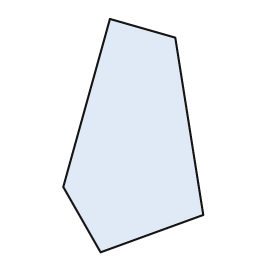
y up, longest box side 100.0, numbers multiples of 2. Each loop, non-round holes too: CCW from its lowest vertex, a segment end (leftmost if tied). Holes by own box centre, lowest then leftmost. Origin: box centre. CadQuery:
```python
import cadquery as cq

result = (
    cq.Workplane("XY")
    .moveTo(-14.0, -50.0)
    .lineTo(30.0, -34.0)
    .lineTo(18.0, 42.0)
    .lineTo(-10.0, 50.0)
    .lineTo(-30.0, -22.0)
    .close()
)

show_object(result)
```